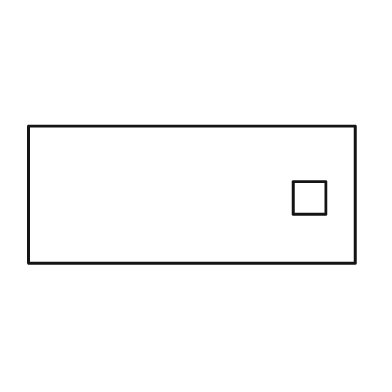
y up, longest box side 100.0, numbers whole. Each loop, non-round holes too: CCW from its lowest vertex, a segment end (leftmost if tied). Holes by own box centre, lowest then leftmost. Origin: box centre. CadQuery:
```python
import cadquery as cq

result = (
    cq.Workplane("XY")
    .moveTo(-50.0, -21.0)
    .lineTo(50.0, -21.0)
    .lineTo(50.0, 21.0)
    .lineTo(-50.0, 21.0)
    .close()
    .moveTo(31.0, -6.0)
    .lineTo(41.0, -6.0)
    .lineTo(41.0, 4.0)
    .lineTo(31.0, 4.0)
    .close()
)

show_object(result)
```